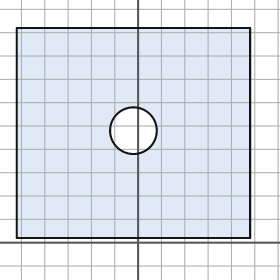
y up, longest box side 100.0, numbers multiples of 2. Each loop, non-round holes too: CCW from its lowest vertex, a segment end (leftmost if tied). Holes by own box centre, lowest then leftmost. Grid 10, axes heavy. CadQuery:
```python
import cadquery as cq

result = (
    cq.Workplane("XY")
    .moveTo(-52.0, 2.0)
    .lineTo(48.0, 2.0)
    .lineTo(48.0, 92.0)
    .lineTo(-52.0, 92.0)
    .close()
    .moveTo(-2.0, 48.0)
    .circle(10.0)
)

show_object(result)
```